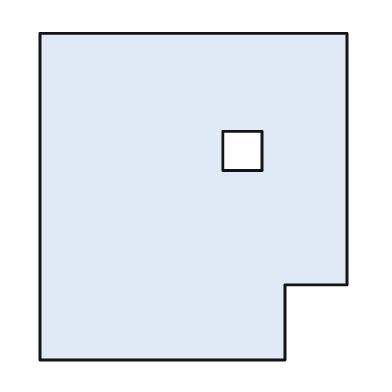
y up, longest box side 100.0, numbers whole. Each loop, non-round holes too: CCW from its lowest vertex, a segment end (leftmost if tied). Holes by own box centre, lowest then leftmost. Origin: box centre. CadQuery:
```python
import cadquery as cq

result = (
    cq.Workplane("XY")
    .moveTo(-47.0, -50.0)
    .lineTo(28.0, -50.0)
    .lineTo(28.0, -27.0)
    .lineTo(47.0, -27.0)
    .lineTo(47.0, 50.0)
    .lineTo(-47.0, 50.0)
    .close()
    .moveTo(9.0, 8.0)
    .lineTo(21.0, 8.0)
    .lineTo(21.0, 20.0)
    .lineTo(9.0, 20.0)
    .close()
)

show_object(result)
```